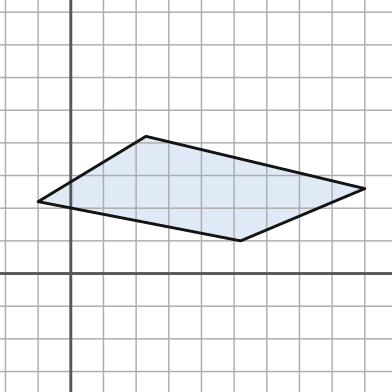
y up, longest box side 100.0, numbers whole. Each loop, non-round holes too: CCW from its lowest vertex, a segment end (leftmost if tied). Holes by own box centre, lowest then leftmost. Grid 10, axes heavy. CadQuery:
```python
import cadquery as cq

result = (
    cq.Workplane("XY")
    .moveTo(52.0, 10.0)
    .lineTo(90.0, 26.0)
    .lineTo(23.0, 42.0)
    .lineTo(-10.0, 22.0)
    .close()
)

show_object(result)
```